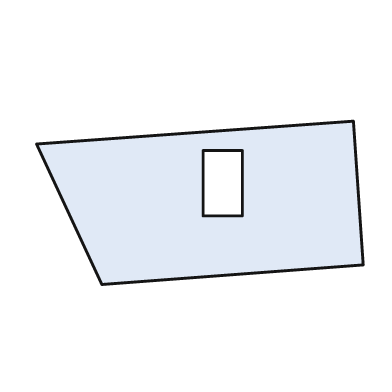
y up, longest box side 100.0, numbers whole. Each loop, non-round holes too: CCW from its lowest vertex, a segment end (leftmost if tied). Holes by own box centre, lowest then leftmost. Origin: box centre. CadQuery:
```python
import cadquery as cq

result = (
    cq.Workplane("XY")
    .moveTo(-30.0, -25.0)
    .lineTo(50.0, -19.0)
    .lineTo(47.0, 25.0)
    .lineTo(-50.0, 18.0)
    .close()
    .moveTo(1.0, -4.0)
    .lineTo(13.0, -4.0)
    .lineTo(13.0, 16.0)
    .lineTo(1.0, 16.0)
    .close()
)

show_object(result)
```